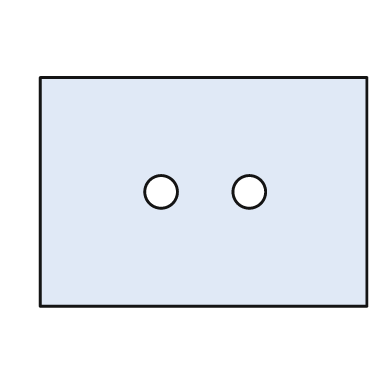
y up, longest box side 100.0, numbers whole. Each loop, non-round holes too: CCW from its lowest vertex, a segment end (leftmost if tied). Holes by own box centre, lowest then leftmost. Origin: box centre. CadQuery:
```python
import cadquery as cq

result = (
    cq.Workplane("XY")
    .moveTo(-50.0, -35.0)
    .lineTo(50.0, -35.0)
    .lineTo(50.0, 35.0)
    .lineTo(-50.0, 35.0)
    .close()
    .moveTo(-13.0, 0.0)
    .circle(5.0)
    .moveTo(14.0, 0.0)
    .circle(5.0)
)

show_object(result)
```